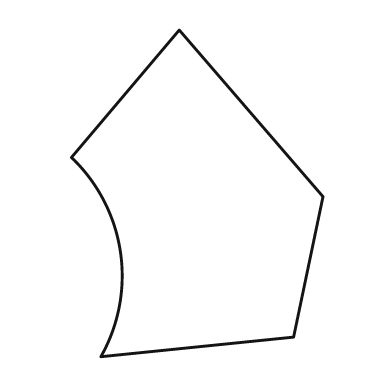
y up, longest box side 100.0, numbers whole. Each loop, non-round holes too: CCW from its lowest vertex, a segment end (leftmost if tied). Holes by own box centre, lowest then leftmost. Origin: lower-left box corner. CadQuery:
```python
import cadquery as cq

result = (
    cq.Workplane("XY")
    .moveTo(9.0, 0.0)
    .lineTo(68.0, 6.0)
    .lineTo(77.0, 49.0)
    .lineTo(33.0, 100.0)
    .lineTo(0.0, 61.0)
    .threePointArc((15.0, 32.0), (9.0, 0.0))
    .close()
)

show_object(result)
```